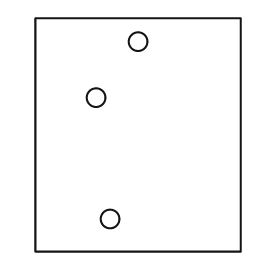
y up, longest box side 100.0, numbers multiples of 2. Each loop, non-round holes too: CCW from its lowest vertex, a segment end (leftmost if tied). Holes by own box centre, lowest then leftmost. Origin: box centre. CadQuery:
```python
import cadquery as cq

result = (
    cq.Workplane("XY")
    .moveTo(-44.0, -50.0)
    .lineTo(44.0, -50.0)
    .lineTo(44.0, 50.0)
    .lineTo(-44.0, 50.0)
    .close()
    .moveTo(-12.0, -36.0)
    .circle(4.0)
    .moveTo(-18.0, 16.0)
    .circle(4.0)
    .moveTo(0.0, 40.0)
    .circle(4.0)
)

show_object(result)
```